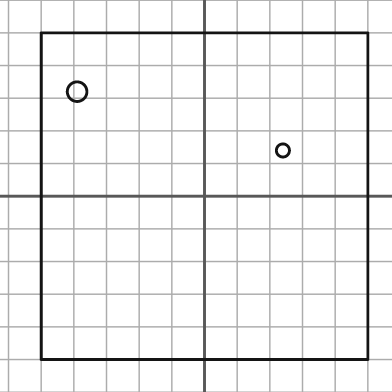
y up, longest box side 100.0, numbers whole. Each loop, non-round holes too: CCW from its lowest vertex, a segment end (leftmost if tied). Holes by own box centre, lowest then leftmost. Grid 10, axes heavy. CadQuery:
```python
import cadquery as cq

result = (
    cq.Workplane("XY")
    .moveTo(-50.0, -50.0)
    .lineTo(50.0, -50.0)
    .lineTo(50.0, 50.0)
    .lineTo(-50.0, 50.0)
    .close()
    .moveTo(24.0, 14.0)
    .circle(2.0)
    .moveTo(-39.0, 32.0)
    .circle(3.0)
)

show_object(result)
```